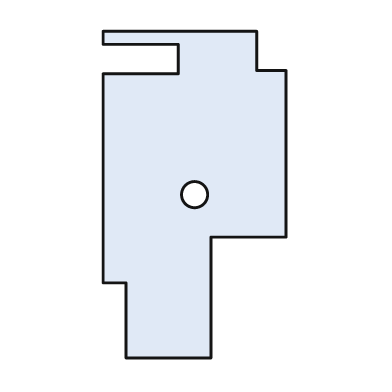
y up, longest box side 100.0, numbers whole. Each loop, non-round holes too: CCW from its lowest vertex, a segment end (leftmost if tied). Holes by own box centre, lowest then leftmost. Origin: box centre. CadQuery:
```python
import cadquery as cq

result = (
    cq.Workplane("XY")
    .moveTo(-21.0, -50.0)
    .lineTo(5.0, -50.0)
    .lineTo(5.0, -13.0)
    .lineTo(28.0, -13.0)
    .lineTo(28.0, 38.0)
    .lineTo(19.0, 38.0)
    .lineTo(19.0, 50.0)
    .lineTo(-28.0, 50.0)
    .lineTo(-28.0, 46.0)
    .lineTo(-5.0, 46.0)
    .lineTo(-5.0, 37.0)
    .lineTo(-28.0, 37.0)
    .lineTo(-28.0, -27.0)
    .lineTo(-21.0, -27.0)
    .close()
    .moveTo(0.0, 0.0)
    .circle(4.0)
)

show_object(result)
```